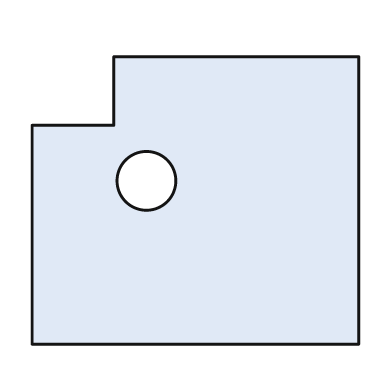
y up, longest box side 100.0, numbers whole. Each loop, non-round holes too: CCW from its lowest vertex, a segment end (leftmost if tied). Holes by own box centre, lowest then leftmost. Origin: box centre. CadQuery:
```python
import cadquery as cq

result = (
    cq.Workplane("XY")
    .moveTo(-50.0, -44.0)
    .lineTo(50.0, -44.0)
    .lineTo(50.0, 44.0)
    .lineTo(-25.0, 44.0)
    .lineTo(-25.0, 23.0)
    .lineTo(-50.0, 23.0)
    .close()
    .moveTo(-15.0, 6.0)
    .circle(9.0)
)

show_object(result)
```